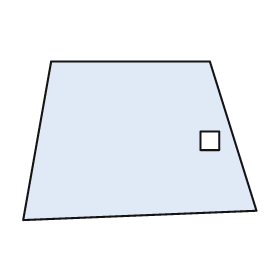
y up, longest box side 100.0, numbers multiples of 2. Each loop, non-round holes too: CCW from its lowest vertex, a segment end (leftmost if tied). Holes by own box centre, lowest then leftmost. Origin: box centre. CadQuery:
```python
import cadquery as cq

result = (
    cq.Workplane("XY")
    .moveTo(-50.0, -34.0)
    .lineTo(50.0, -30.0)
    .lineTo(30.0, 34.0)
    .lineTo(-38.0, 34.0)
    .close()
    .moveTo(26.0, -4.0)
    .lineTo(34.0, -4.0)
    .lineTo(34.0, 4.0)
    .lineTo(26.0, 4.0)
    .close()
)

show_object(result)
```